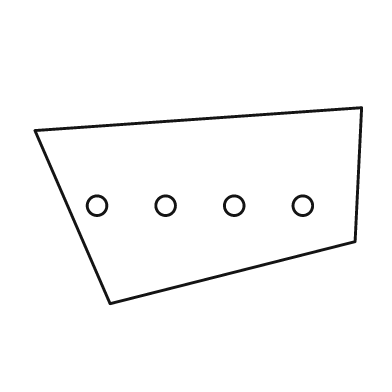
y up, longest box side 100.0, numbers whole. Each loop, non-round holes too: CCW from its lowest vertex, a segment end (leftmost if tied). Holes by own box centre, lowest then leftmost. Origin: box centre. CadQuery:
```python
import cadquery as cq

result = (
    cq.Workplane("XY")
    .moveTo(-27.0, -30.0)
    .lineTo(48.0, -11.0)
    .lineTo(50.0, 30.0)
    .lineTo(-50.0, 23.0)
    .close()
    .moveTo(-31.0, 0.0)
    .circle(3.0)
    .moveTo(-10.0, 0.0)
    .circle(3.0)
    .moveTo(11.0, 0.0)
    .circle(3.0)
    .moveTo(32.0, 0.0)
    .circle(3.0)
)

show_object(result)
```